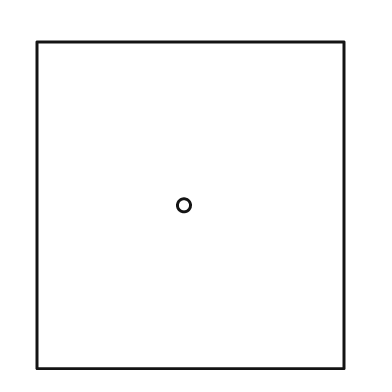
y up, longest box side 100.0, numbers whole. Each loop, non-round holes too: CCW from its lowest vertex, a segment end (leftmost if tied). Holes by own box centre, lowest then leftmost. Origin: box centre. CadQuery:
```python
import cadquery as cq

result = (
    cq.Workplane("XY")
    .moveTo(-47.0, -50.0)
    .lineTo(47.0, -50.0)
    .lineTo(47.0, 50.0)
    .lineTo(-47.0, 50.0)
    .close()
    .moveTo(-2.0, 0.0)
    .circle(2.0)
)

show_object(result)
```